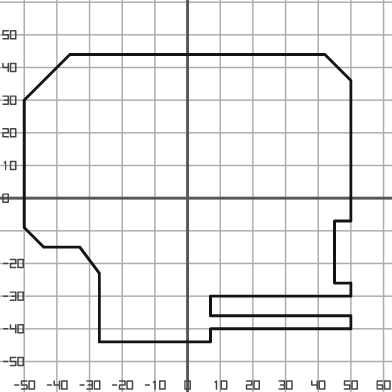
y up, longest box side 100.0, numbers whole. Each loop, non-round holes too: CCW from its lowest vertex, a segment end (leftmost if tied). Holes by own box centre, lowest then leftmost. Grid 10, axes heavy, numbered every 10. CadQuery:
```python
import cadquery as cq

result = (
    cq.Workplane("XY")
    .moveTo(-27.0, -44.0)
    .lineTo(7.0, -44.0)
    .lineTo(7.0, -40.0)
    .lineTo(50.0, -40.0)
    .lineTo(50.0, -36.0)
    .lineTo(7.0, -36.0)
    .lineTo(7.0, -30.0)
    .lineTo(50.0, -30.0)
    .lineTo(50.0, -26.0)
    .lineTo(45.0, -26.0)
    .lineTo(45.0, -7.0)
    .lineTo(50.0, -7.0)
    .lineTo(50.0, 36.0)
    .lineTo(42.0, 44.0)
    .lineTo(-36.0, 44.0)
    .lineTo(-50.0, 30.0)
    .lineTo(-50.0, -9.0)
    .lineTo(-44.0, -15.0)
    .lineTo(-33.0, -15.0)
    .lineTo(-27.0, -23.0)
    .close()
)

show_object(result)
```